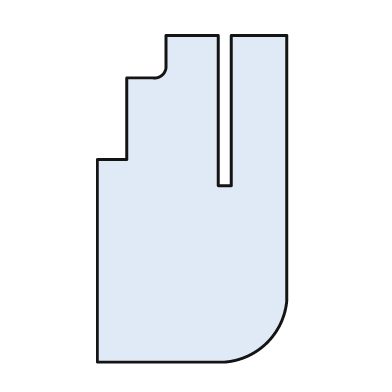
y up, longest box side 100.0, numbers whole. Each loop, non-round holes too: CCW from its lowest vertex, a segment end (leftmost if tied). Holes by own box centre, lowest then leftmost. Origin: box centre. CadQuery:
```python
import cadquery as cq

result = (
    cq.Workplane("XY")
    .moveTo(-29.0, -50.0)
    .lineTo(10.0, -50.0)
    .threePointArc((23.0, -44.0), (29.0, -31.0))
    .lineTo(29.0, 50.0)
    .lineTo(12.0, 50.0)
    .lineTo(12.0, 4.0)
    .lineTo(8.0, 4.0)
    .lineTo(8.0, 50.0)
    .lineTo(-8.0, 50.0)
    .lineTo(-8.0, 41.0)
    .threePointArc((-9.0, 38.0), (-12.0, 37.0))
    .lineTo(-20.0, 37.0)
    .lineTo(-20.0, 12.0)
    .lineTo(-29.0, 12.0)
    .close()
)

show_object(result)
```